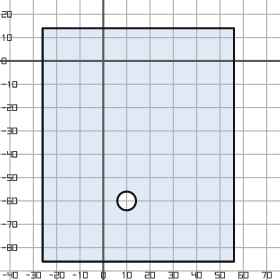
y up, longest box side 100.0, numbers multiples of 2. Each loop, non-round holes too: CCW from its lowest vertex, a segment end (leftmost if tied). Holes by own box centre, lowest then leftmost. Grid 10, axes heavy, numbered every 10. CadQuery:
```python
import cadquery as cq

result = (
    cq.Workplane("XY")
    .moveTo(-26.0, -86.0)
    .lineTo(56.0, -86.0)
    .lineTo(56.0, 14.0)
    .lineTo(-26.0, 14.0)
    .close()
    .moveTo(10.0, -60.0)
    .circle(4.0)
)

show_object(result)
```